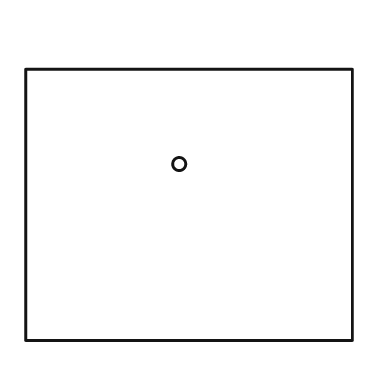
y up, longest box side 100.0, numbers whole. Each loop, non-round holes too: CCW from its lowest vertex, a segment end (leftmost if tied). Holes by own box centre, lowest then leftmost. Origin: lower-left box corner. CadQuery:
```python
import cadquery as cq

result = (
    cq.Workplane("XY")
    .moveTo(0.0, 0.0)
    .lineTo(100.0, 0.0)
    .lineTo(100.0, 83.0)
    .lineTo(0.0, 83.0)
    .close()
    .moveTo(47.0, 54.0)
    .circle(2.0)
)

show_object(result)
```